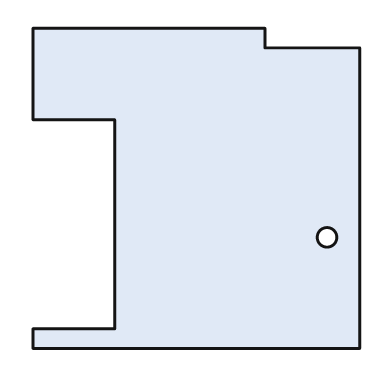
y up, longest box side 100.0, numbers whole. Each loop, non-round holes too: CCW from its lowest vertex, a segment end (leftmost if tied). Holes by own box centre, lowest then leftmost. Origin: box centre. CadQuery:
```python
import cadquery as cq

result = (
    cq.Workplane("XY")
    .moveTo(-50.0, -49.0)
    .lineTo(50.0, -49.0)
    .lineTo(50.0, 43.0)
    .lineTo(21.0, 43.0)
    .lineTo(21.0, 49.0)
    .lineTo(-50.0, 49.0)
    .lineTo(-50.0, 21.0)
    .lineTo(-25.0, 21.0)
    .lineTo(-25.0, -43.0)
    .lineTo(-50.0, -43.0)
    .close()
    .moveTo(40.0, -15.0)
    .circle(3.0)
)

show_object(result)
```